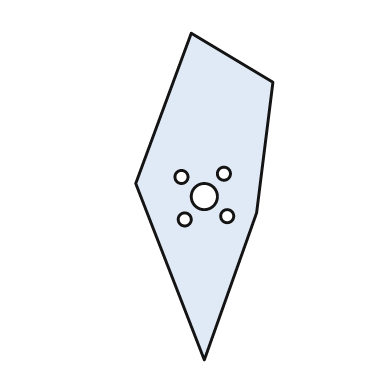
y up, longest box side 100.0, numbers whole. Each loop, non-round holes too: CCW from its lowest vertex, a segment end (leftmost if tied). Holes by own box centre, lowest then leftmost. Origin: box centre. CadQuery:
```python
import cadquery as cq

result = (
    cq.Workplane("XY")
    .moveTo(0.0, -50.0)
    .lineTo(16.0, -5.0)
    .lineTo(21.0, 35.0)
    .lineTo(-4.0, 50.0)
    .lineTo(-21.0, 4.0)
    .close()
    .moveTo(-6.0, -7.0)
    .circle(2.0)
    .moveTo(7.0, -6.0)
    .circle(2.0)
    .moveTo(0.0, 0.0)
    .circle(4.0)
    .moveTo(-7.0, 6.0)
    .circle(2.0)
    .moveTo(6.0, 7.0)
    .circle(2.0)
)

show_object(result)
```